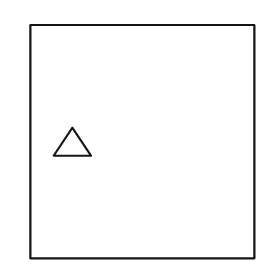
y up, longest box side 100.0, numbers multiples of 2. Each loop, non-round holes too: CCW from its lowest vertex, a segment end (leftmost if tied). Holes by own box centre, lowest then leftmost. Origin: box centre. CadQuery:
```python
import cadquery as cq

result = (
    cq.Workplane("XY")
    .moveTo(-48.0, -50.0)
    .lineTo(48.0, -50.0)
    .lineTo(48.0, 50.0)
    .lineTo(-48.0, 50.0)
    .close()
    .moveTo(-38.0, -6.0)
    .lineTo(-22.0, -6.0)
    .lineTo(-30.0, 6.0)
    .close()
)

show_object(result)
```